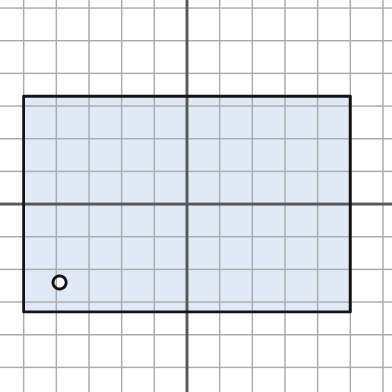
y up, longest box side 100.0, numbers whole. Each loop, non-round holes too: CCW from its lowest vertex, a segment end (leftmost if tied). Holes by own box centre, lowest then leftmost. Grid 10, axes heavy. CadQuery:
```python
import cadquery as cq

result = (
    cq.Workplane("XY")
    .moveTo(-50.0, -33.0)
    .lineTo(50.0, -33.0)
    .lineTo(50.0, 33.0)
    .lineTo(-50.0, 33.0)
    .close()
    .moveTo(-39.0, -24.0)
    .circle(2.0)
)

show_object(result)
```